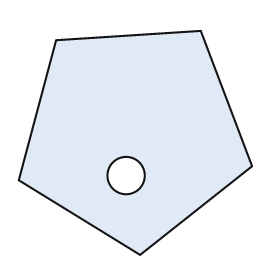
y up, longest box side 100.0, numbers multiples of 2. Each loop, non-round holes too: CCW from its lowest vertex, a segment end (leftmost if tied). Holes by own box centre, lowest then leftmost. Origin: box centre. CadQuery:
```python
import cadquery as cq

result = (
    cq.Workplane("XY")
    .moveTo(2.0, -48.0)
    .lineTo(50.0, -10.0)
    .lineTo(28.0, 48.0)
    .lineTo(-34.0, 44.0)
    .lineTo(-50.0, -16.0)
    .close()
    .moveTo(-4.0, -14.0)
    .circle(8.0)
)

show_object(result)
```